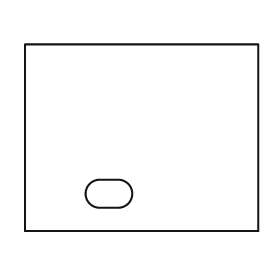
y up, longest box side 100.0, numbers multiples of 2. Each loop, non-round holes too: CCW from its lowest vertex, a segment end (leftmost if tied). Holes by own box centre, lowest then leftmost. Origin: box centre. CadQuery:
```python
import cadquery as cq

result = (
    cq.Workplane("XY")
    .moveTo(-50.0, -40.0)
    .lineTo(50.0, -40.0)
    .lineTo(50.0, 40.0)
    .lineTo(-50.0, 40.0)
    .close()
    .moveTo(-18.0, -30.0)
    .lineTo(-10.0, -30.0)
    .threePointArc((-4.0, -24.0), (-10.0, -18.0))
    .lineTo(-18.0, -18.0)
    .threePointArc((-24.0, -24.0), (-18.0, -30.0))
    .close()
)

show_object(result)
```